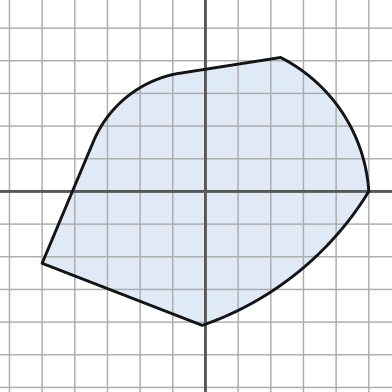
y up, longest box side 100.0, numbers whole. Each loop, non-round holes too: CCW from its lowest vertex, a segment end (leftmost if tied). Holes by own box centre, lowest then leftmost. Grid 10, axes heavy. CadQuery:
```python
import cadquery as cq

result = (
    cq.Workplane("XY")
    .moveTo(-1.0, -41.0)
    .threePointArc((28.0, -25.0), (50.0, 0.0))
    .threePointArc((42.0, 24.0), (23.0, 41.0))
    .lineTo(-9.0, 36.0)
    .threePointArc((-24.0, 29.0), (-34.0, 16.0))
    .lineTo(-50.0, -22.0)
    .close()
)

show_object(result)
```